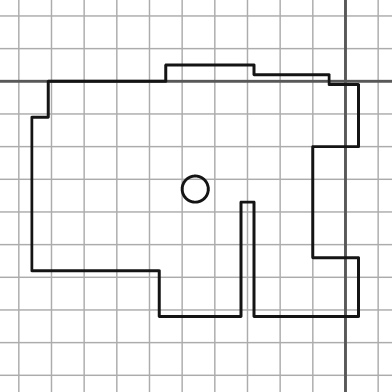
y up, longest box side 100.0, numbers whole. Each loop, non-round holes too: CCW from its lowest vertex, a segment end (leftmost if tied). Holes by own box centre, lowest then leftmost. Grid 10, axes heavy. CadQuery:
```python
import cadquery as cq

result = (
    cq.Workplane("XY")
    .moveTo(-57.0, -72.0)
    .lineTo(-32.0, -72.0)
    .lineTo(-32.0, -37.0)
    .lineTo(-28.0, -37.0)
    .lineTo(-28.0, -72.0)
    .lineTo(4.0, -72.0)
    .lineTo(4.0, -54.0)
    .lineTo(-10.0, -54.0)
    .lineTo(-10.0, -20.0)
    .lineTo(4.0, -20.0)
    .lineTo(4.0, -1.0)
    .lineTo(-5.0, -1.0)
    .lineTo(-5.0, 2.0)
    .lineTo(-28.0, 2.0)
    .lineTo(-28.0, 5.0)
    .lineTo(-55.0, 5.0)
    .lineTo(-55.0, 0.0)
    .lineTo(-91.0, 0.0)
    .lineTo(-91.0, -11.0)
    .lineTo(-96.0, -11.0)
    .lineTo(-96.0, -58.0)
    .lineTo(-57.0, -58.0)
    .close()
    .moveTo(-46.0, -33.0)
    .circle(4.0)
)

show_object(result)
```